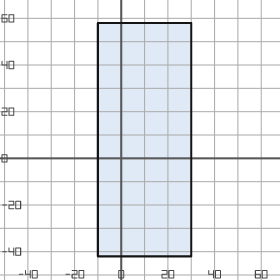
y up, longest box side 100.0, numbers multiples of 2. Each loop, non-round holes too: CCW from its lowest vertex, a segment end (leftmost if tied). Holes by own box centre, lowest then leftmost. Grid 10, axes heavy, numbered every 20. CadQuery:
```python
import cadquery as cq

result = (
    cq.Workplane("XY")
    .moveTo(-10.0, -42.0)
    .lineTo(30.0, -42.0)
    .lineTo(30.0, 58.0)
    .lineTo(-10.0, 58.0)
    .close()
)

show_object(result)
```